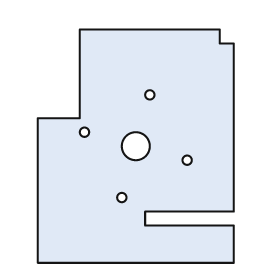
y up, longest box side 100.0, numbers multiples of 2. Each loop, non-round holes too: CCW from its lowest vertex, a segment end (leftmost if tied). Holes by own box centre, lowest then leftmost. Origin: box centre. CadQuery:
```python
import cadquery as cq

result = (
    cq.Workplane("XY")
    .moveTo(-42.0, -50.0)
    .lineTo(42.0, -50.0)
    .lineTo(42.0, -34.0)
    .lineTo(4.0, -34.0)
    .lineTo(4.0, -28.0)
    .lineTo(42.0, -28.0)
    .lineTo(42.0, 44.0)
    .lineTo(36.0, 44.0)
    .lineTo(36.0, 50.0)
    .lineTo(-24.0, 50.0)
    .lineTo(-24.0, 12.0)
    .lineTo(-42.0, 12.0)
    .close()
    .moveTo(-6.0, -22.0)
    .circle(2.0)
    .moveTo(22.0, -6.0)
    .circle(2.0)
    .moveTo(0.0, 0.0)
    .circle(6.0)
    .moveTo(-22.0, 6.0)
    .circle(2.0)
    .moveTo(6.0, 22.0)
    .circle(2.0)
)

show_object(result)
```